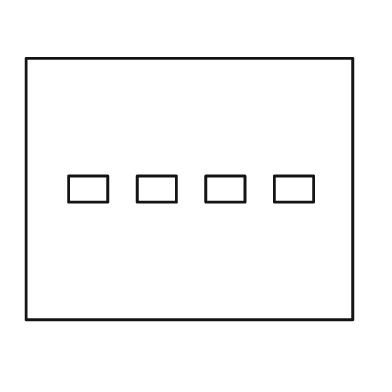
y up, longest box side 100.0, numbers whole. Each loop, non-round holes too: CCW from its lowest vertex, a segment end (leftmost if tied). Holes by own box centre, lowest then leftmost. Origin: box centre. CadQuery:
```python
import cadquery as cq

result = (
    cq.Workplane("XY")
    .moveTo(-50.0, -40.0)
    .lineTo(50.0, -40.0)
    .lineTo(50.0, 40.0)
    .lineTo(-50.0, 40.0)
    .close()
    .moveTo(-37.0, -4.0)
    .lineTo(-25.0, -4.0)
    .lineTo(-25.0, 4.0)
    .lineTo(-37.0, 4.0)
    .close()
    .moveTo(-16.0, -4.0)
    .lineTo(-4.0, -4.0)
    .lineTo(-4.0, 4.0)
    .lineTo(-16.0, 4.0)
    .close()
    .moveTo(5.0, -4.0)
    .lineTo(17.0, -4.0)
    .lineTo(17.0, 4.0)
    .lineTo(5.0, 4.0)
    .close()
    .moveTo(26.0, -4.0)
    .lineTo(38.0, -4.0)
    .lineTo(38.0, 4.0)
    .lineTo(26.0, 4.0)
    .close()
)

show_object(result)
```